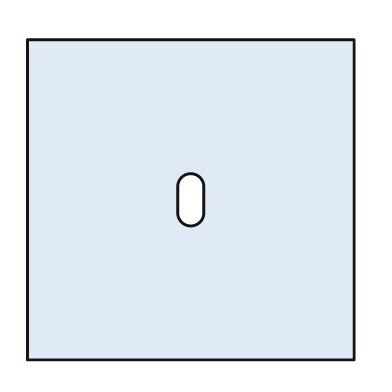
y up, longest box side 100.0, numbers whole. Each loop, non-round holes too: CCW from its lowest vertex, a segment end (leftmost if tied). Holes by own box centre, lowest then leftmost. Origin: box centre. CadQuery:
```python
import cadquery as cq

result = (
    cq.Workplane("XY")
    .moveTo(-50.0, -49.0)
    .lineTo(50.0, -49.0)
    .lineTo(50.0, 49.0)
    .lineTo(-50.0, 49.0)
    .close()
    .moveTo(-4.0, -4.0)
    .threePointArc((0.0, -8.0), (4.0, -4.0))
    .lineTo(4.0, 4.0)
    .threePointArc((0.0, 8.0), (-4.0, 4.0))
    .close()
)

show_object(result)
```